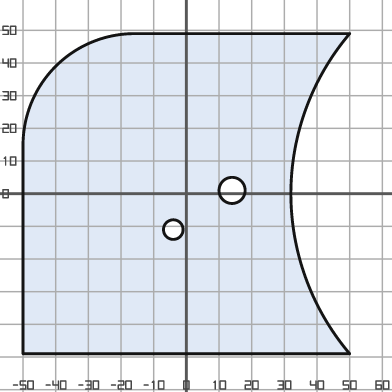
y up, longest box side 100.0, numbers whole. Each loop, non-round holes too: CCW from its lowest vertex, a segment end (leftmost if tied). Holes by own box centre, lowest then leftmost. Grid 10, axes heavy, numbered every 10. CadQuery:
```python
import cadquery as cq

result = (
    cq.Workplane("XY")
    .moveTo(-50.0, -49.0)
    .lineTo(50.0, -49.0)
    .threePointArc((32.0, 0.0), (50.0, 49.0))
    .lineTo(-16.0, 49.0)
    .threePointArc((-40.0, 39.0), (-50.0, 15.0))
    .close()
    .moveTo(-4.0, -11.0)
    .circle(3.0)
    .moveTo(14.0, 1.0)
    .circle(4.0)
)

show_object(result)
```